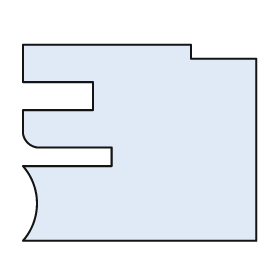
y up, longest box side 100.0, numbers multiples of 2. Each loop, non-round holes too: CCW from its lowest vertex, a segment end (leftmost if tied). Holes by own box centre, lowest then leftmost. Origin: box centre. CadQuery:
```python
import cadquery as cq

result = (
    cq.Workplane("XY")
    .moveTo(-50.0, -42.0)
    .lineTo(50.0, -42.0)
    .lineTo(50.0, 36.0)
    .lineTo(22.0, 36.0)
    .lineTo(22.0, 42.0)
    .lineTo(-50.0, 42.0)
    .lineTo(-50.0, 26.0)
    .lineTo(-20.0, 26.0)
    .lineTo(-20.0, 14.0)
    .lineTo(-50.0, 14.0)
    .lineTo(-50.0, 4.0)
    .threePointArc((-48.0, 0.0), (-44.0, -2.0))
    .lineTo(-12.0, -2.0)
    .lineTo(-12.0, -10.0)
    .lineTo(-50.0, -10.0)
    .threePointArc((-44.0, -26.0), (-50.0, -42.0))
    .close()
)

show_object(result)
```